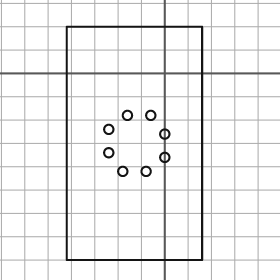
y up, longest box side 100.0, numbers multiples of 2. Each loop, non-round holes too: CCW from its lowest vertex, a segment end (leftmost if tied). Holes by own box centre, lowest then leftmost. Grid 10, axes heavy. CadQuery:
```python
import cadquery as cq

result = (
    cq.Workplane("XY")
    .moveTo(-42.0, -80.0)
    .lineTo(16.0, -80.0)
    .lineTo(16.0, 20.0)
    .lineTo(-42.0, 20.0)
    .close()
    .moveTo(-18.0, -42.0)
    .circle(2.0)
    .moveTo(-8.0, -42.0)
    .circle(2.0)
    .moveTo(0.0, -36.0)
    .circle(2.0)
    .moveTo(-24.0, -34.0)
    .circle(2.0)
    .moveTo(0.0, -26.0)
    .circle(2.0)
    .moveTo(-24.0, -24.0)
    .circle(2.0)
    .moveTo(-16.0, -18.0)
    .circle(2.0)
    .moveTo(-6.0, -18.0)
    .circle(2.0)
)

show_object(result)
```